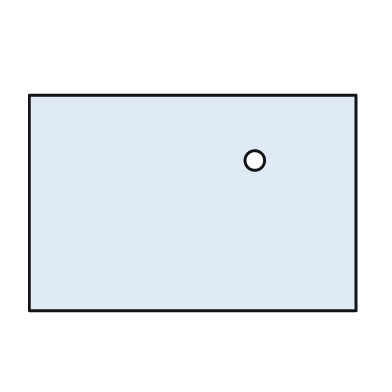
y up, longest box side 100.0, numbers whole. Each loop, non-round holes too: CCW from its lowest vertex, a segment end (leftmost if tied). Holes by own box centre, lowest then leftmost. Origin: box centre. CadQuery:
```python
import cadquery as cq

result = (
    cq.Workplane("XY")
    .moveTo(-50.0, -33.0)
    .lineTo(50.0, -33.0)
    .lineTo(50.0, 33.0)
    .lineTo(-50.0, 33.0)
    .close()
    .moveTo(19.0, 13.0)
    .circle(3.0)
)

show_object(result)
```